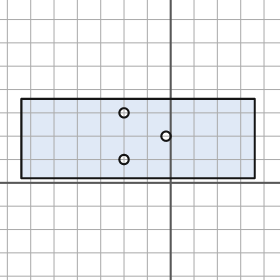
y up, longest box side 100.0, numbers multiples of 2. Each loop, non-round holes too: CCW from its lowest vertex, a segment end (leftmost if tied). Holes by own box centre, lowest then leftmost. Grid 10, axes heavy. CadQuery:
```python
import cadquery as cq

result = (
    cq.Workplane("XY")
    .moveTo(-64.0, 2.0)
    .lineTo(36.0, 2.0)
    .lineTo(36.0, 36.0)
    .lineTo(-64.0, 36.0)
    .close()
    .moveTo(-20.0, 10.0)
    .circle(2.0)
    .moveTo(-2.0, 20.0)
    .circle(2.0)
    .moveTo(-20.0, 30.0)
    .circle(2.0)
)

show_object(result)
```